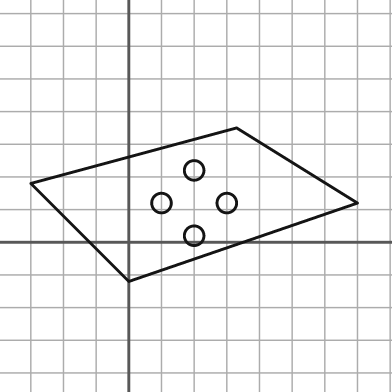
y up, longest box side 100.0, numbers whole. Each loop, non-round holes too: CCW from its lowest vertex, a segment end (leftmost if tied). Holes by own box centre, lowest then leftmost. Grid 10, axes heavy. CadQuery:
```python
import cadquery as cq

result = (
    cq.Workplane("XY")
    .moveTo(0.0, -12.0)
    .lineTo(70.0, 12.0)
    .lineTo(33.0, 35.0)
    .lineTo(-30.0, 18.0)
    .close()
    .moveTo(20.0, 2.0)
    .circle(3.0)
    .moveTo(10.0, 12.0)
    .circle(3.0)
    .moveTo(30.0, 12.0)
    .circle(3.0)
    .moveTo(20.0, 22.0)
    .circle(3.0)
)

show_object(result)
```